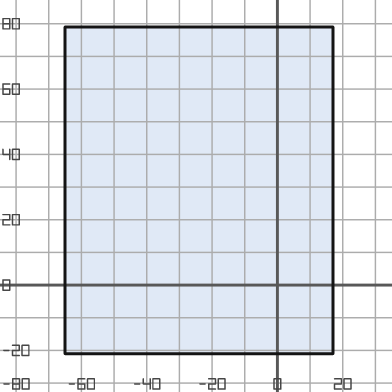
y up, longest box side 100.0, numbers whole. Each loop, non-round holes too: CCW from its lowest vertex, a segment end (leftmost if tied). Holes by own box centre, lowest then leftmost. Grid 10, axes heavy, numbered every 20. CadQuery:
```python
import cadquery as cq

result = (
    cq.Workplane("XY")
    .moveTo(-65.0, -21.0)
    .lineTo(17.0, -21.0)
    .lineTo(17.0, 79.0)
    .lineTo(-65.0, 79.0)
    .close()
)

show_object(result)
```